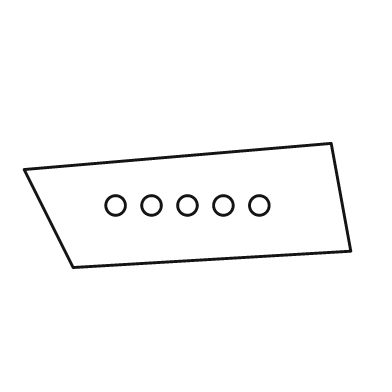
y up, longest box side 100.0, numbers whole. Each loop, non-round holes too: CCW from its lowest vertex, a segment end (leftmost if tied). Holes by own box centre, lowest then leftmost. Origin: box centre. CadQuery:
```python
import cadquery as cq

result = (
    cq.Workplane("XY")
    .moveTo(-35.0, -19.0)
    .lineTo(50.0, -14.0)
    .lineTo(44.0, 19.0)
    .lineTo(-50.0, 11.0)
    .close()
    .moveTo(-22.0, 0.0)
    .circle(3.0)
    .moveTo(-11.0, 0.0)
    .circle(3.0)
    .moveTo(0.0, 0.0)
    .circle(3.0)
    .moveTo(11.0, 0.0)
    .circle(3.0)
    .moveTo(22.0, 0.0)
    .circle(3.0)
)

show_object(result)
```